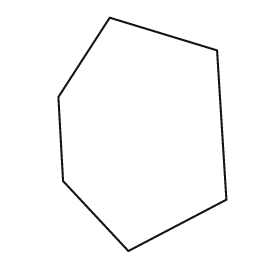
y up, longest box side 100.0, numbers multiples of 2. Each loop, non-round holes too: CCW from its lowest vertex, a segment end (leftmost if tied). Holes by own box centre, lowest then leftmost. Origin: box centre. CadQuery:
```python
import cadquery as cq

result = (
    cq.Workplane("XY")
    .moveTo(-6.0, -50.0)
    .lineTo(36.0, -28.0)
    .lineTo(32.0, 36.0)
    .lineTo(-14.0, 50.0)
    .lineTo(-36.0, 16.0)
    .lineTo(-34.0, -20.0)
    .close()
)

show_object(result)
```